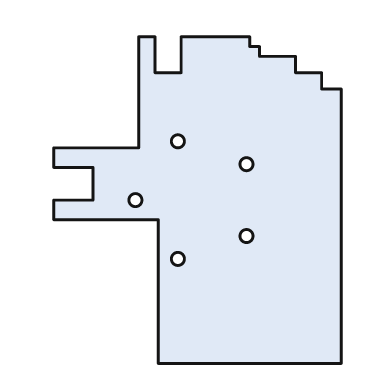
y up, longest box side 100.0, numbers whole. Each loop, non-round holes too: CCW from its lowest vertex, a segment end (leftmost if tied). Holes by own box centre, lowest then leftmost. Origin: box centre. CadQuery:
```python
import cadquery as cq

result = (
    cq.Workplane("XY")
    .moveTo(-12.0, -50.0)
    .lineTo(44.0, -50.0)
    .lineTo(44.0, 34.0)
    .lineTo(38.0, 34.0)
    .lineTo(38.0, 39.0)
    .lineTo(30.0, 39.0)
    .lineTo(30.0, 44.0)
    .lineTo(19.0, 44.0)
    .lineTo(19.0, 47.0)
    .lineTo(16.0, 47.0)
    .lineTo(16.0, 50.0)
    .lineTo(-5.0, 50.0)
    .lineTo(-5.0, 39.0)
    .lineTo(-13.0, 39.0)
    .lineTo(-13.0, 50.0)
    .lineTo(-18.0, 50.0)
    .lineTo(-18.0, 16.0)
    .lineTo(-44.0, 16.0)
    .lineTo(-44.0, 10.0)
    .lineTo(-32.0, 10.0)
    .lineTo(-32.0, 0.0)
    .lineTo(-44.0, 0.0)
    .lineTo(-44.0, -6.0)
    .lineTo(-12.0, -6.0)
    .close()
    .moveTo(-6.0, -18.0)
    .circle(2.0)
    .moveTo(15.0, -11.0)
    .circle(2.0)
    .moveTo(-19.0, 0.0)
    .circle(2.0)
    .moveTo(15.0, 11.0)
    .circle(2.0)
    .moveTo(-6.0, 18.0)
    .circle(2.0)
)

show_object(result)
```